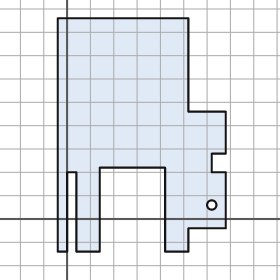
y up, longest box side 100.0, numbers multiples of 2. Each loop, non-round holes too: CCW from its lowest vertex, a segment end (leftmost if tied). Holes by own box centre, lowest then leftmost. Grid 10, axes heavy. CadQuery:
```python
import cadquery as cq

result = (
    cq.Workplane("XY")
    .moveTo(-4.0, -14.0)
    .lineTo(0.0, -14.0)
    .lineTo(0.0, 20.0)
    .lineTo(4.0, 20.0)
    .lineTo(4.0, -14.0)
    .lineTo(14.0, -14.0)
    .lineTo(14.0, 22.0)
    .lineTo(42.0, 22.0)
    .lineTo(42.0, -14.0)
    .lineTo(52.0, -14.0)
    .lineTo(52.0, -4.0)
    .lineTo(68.0, -4.0)
    .lineTo(68.0, 20.0)
    .lineTo(62.0, 20.0)
    .lineTo(62.0, 28.0)
    .lineTo(68.0, 28.0)
    .lineTo(68.0, 46.0)
    .lineTo(52.0, 46.0)
    .lineTo(52.0, 86.0)
    .lineTo(-4.0, 86.0)
    .close()
    .moveTo(62.0, 6.0)
    .circle(2.0)
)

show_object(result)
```